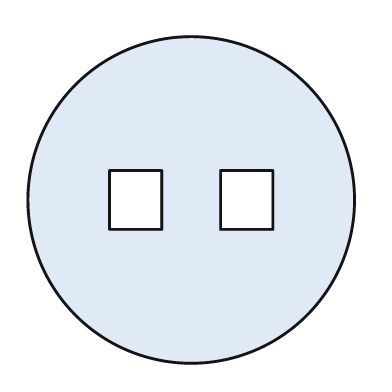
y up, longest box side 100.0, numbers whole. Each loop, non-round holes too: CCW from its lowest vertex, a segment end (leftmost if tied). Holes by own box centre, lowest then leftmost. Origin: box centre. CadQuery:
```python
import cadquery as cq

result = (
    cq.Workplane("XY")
    .moveTo(0.0, 0.0)
    .circle(50.0)
    .moveTo(-25.0, -9.0)
    .lineTo(-9.0, -9.0)
    .lineTo(-9.0, 9.0)
    .lineTo(-25.0, 9.0)
    .close()
    .moveTo(9.0, -9.0)
    .lineTo(25.0, -9.0)
    .lineTo(25.0, 9.0)
    .lineTo(9.0, 9.0)
    .close()
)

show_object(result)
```